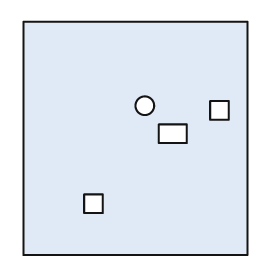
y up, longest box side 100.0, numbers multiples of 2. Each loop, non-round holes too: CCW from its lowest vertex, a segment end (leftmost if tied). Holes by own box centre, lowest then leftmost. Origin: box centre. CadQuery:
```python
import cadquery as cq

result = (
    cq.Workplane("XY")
    .moveTo(-48.0, -50.0)
    .lineTo(48.0, -50.0)
    .lineTo(48.0, 50.0)
    .lineTo(-48.0, 50.0)
    .close()
    .moveTo(-22.0, -32.0)
    .lineTo(-14.0, -32.0)
    .lineTo(-14.0, -24.0)
    .lineTo(-22.0, -24.0)
    .close()
    .moveTo(10.0, -2.0)
    .lineTo(22.0, -2.0)
    .lineTo(22.0, 6.0)
    .lineTo(10.0, 6.0)
    .close()
    .moveTo(32.0, 8.0)
    .lineTo(40.0, 8.0)
    .lineTo(40.0, 16.0)
    .lineTo(32.0, 16.0)
    .close()
    .moveTo(4.0, 14.0)
    .circle(4.0)
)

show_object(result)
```